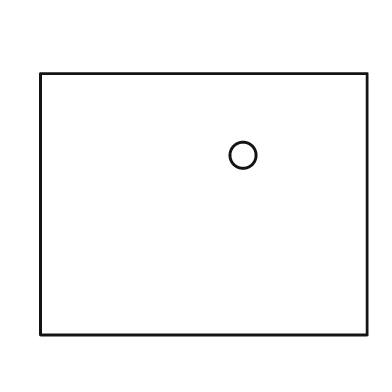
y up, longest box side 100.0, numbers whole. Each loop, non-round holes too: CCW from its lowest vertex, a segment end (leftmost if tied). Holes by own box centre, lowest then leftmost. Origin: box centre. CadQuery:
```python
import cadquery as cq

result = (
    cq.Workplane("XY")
    .moveTo(-50.0, -40.0)
    .lineTo(50.0, -40.0)
    .lineTo(50.0, 40.0)
    .lineTo(-50.0, 40.0)
    .close()
    .moveTo(12.0, 15.0)
    .circle(4.0)
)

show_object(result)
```